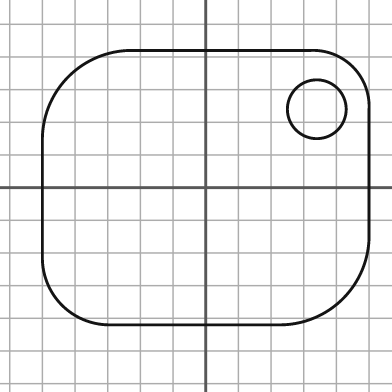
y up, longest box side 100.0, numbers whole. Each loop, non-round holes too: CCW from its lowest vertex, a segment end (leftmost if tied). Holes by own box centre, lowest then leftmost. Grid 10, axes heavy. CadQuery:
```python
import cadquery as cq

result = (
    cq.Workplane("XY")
    .moveTo(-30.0, -42.0)
    .lineTo(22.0, -42.0)
    .threePointArc((42.0, -34.0), (50.0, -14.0))
    .lineTo(50.0, 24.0)
    .threePointArc((45.0, 37.0), (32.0, 42.0))
    .lineTo(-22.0, 42.0)
    .threePointArc((-42.0, 34.0), (-50.0, 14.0))
    .lineTo(-50.0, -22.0)
    .threePointArc((-44.0, -36.0), (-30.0, -42.0))
    .close()
    .moveTo(34.0, 24.0)
    .circle(9.0)
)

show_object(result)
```